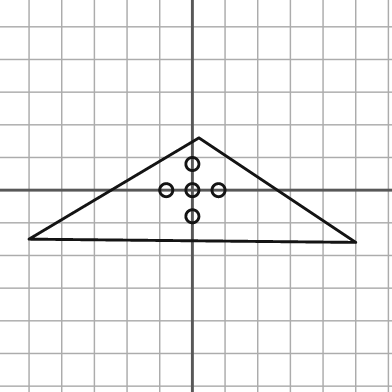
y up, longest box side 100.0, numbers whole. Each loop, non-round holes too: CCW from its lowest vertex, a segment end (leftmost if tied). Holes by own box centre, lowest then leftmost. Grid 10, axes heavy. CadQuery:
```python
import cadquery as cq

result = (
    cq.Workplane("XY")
    .moveTo(50.0, -16.0)
    .lineTo(2.0, 16.0)
    .lineTo(-50.0, -15.0)
    .close()
    .moveTo(0.0, -8.0)
    .circle(2.0)
    .moveTo(-8.0, 0.0)
    .circle(2.0)
    .moveTo(0.0, 0.0)
    .circle(2.0)
    .moveTo(8.0, 0.0)
    .circle(2.0)
    .moveTo(0.0, 8.0)
    .circle(2.0)
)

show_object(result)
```